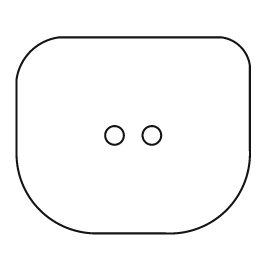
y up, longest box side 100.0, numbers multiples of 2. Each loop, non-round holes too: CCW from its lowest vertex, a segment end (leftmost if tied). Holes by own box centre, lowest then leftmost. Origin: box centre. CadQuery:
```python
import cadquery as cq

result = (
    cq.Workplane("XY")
    .moveTo(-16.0, -42.0)
    .lineTo(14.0, -42.0)
    .threePointArc((40.0, -32.0), (50.0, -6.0))
    .lineTo(50.0, 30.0)
    .threePointArc((46.0, 38.0), (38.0, 42.0))
    .lineTo(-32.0, 42.0)
    .threePointArc((-44.0, 36.0), (-50.0, 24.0))
    .lineTo(-50.0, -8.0)
    .threePointArc((-40.0, -32.0), (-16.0, -42.0))
    .close()
    .moveTo(-8.0, 0.0)
    .circle(4.0)
    .moveTo(8.0, 0.0)
    .circle(4.0)
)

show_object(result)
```